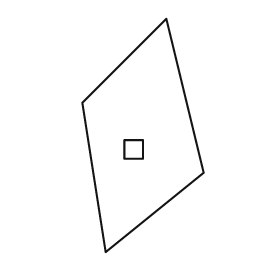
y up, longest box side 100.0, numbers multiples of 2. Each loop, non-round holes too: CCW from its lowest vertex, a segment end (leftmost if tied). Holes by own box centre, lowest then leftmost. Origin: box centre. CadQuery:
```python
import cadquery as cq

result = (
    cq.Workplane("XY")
    .moveTo(-16.0, -50.0)
    .lineTo(26.0, -16.0)
    .lineTo(10.0, 50.0)
    .lineTo(-26.0, 14.0)
    .close()
    .moveTo(-8.0, -10.0)
    .lineTo(0.0, -10.0)
    .lineTo(0.0, -2.0)
    .lineTo(-8.0, -2.0)
    .close()
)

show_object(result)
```